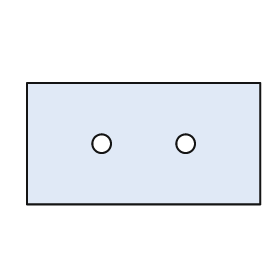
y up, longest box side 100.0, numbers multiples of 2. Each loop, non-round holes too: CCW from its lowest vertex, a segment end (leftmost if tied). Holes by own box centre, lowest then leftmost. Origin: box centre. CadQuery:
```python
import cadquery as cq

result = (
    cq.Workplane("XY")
    .moveTo(-50.0, -26.0)
    .lineTo(50.0, -26.0)
    .lineTo(50.0, 26.0)
    .lineTo(-50.0, 26.0)
    .close()
    .moveTo(-18.0, 0.0)
    .circle(4.0)
    .moveTo(18.0, 0.0)
    .circle(4.0)
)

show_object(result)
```